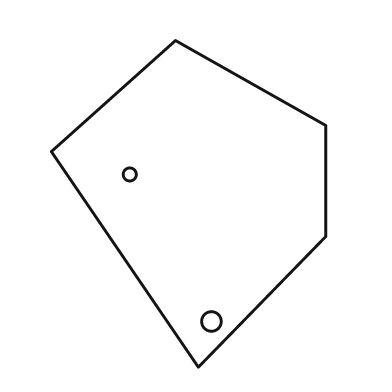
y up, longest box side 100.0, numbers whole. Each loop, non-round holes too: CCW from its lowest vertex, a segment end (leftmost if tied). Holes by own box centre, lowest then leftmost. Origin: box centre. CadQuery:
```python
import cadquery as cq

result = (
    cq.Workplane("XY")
    .moveTo(3.0, -50.0)
    .lineTo(42.0, -10.0)
    .lineTo(42.0, 24.0)
    .lineTo(-4.0, 50.0)
    .lineTo(-42.0, 16.0)
    .close()
    .moveTo(7.0, -36.0)
    .circle(3.0)
    .moveTo(-18.0, 9.0)
    .circle(2.0)
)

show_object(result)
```